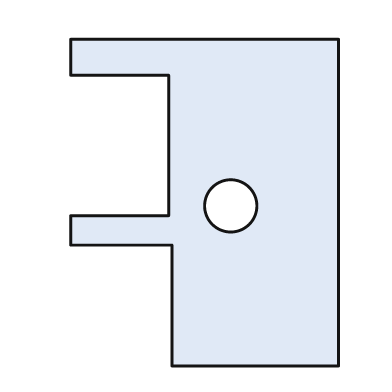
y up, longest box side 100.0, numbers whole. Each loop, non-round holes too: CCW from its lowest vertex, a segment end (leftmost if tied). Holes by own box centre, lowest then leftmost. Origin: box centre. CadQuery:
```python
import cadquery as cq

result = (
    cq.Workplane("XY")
    .moveTo(-10.0, -50.0)
    .lineTo(41.0, -50.0)
    .lineTo(41.0, 50.0)
    .lineTo(-41.0, 50.0)
    .lineTo(-41.0, 39.0)
    .lineTo(-11.0, 39.0)
    .lineTo(-11.0, -4.0)
    .lineTo(-41.0, -4.0)
    .lineTo(-41.0, -13.0)
    .lineTo(-10.0, -13.0)
    .close()
    .moveTo(8.0, -1.0)
    .circle(8.0)
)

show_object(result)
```